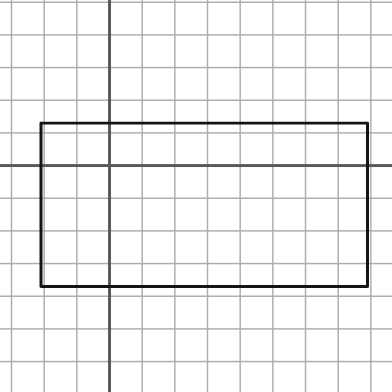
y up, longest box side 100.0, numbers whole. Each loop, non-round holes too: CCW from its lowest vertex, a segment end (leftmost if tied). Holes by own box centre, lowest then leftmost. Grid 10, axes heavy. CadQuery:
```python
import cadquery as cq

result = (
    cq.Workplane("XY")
    .moveTo(-21.0, -37.0)
    .lineTo(79.0, -37.0)
    .lineTo(79.0, 13.0)
    .lineTo(-21.0, 13.0)
    .close()
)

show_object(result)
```